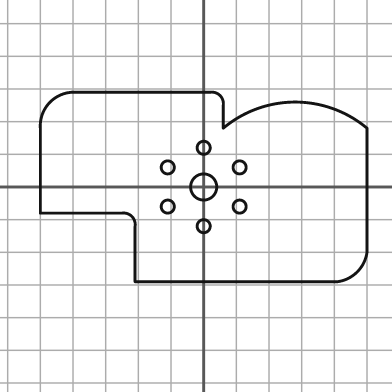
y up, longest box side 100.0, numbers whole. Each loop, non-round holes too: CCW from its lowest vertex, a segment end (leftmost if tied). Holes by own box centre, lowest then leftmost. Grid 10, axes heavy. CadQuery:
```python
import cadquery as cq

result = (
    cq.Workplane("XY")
    .moveTo(-21.0, -29.0)
    .lineTo(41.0, -29.0)
    .threePointArc((47.0, -26.0), (50.0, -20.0))
    .lineTo(50.0, 18.0)
    .threePointArc((28.0, 26.0), (6.0, 18.0))
    .lineTo(6.0, 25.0)
    .threePointArc((5.0, 28.0), (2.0, 29.0))
    .lineTo(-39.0, 29.0)
    .threePointArc((-47.0, 26.0), (-50.0, 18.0))
    .lineTo(-50.0, -8.0)
    .lineTo(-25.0, -8.0)
    .threePointArc((-22.0, -9.0), (-21.0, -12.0))
    .close()
    .moveTo(0.0, -12.0)
    .circle(2.0)
    .moveTo(-11.0, -6.0)
    .circle(2.0)
    .moveTo(11.0, -6.0)
    .circle(2.0)
    .moveTo(0.0, 0.0)
    .circle(4.0)
    .moveTo(-11.0, 6.0)
    .circle(2.0)
    .moveTo(11.0, 6.0)
    .circle(2.0)
    .moveTo(0.0, 12.0)
    .circle(2.0)
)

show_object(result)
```